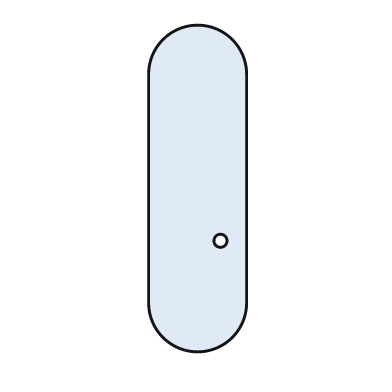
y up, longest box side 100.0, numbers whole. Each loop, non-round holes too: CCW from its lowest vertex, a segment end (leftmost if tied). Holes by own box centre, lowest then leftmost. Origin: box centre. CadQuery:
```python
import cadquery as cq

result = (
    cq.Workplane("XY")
    .moveTo(-15.0, -35.0)
    .threePointArc((0.0, -50.0), (15.0, -35.0))
    .lineTo(15.0, 35.0)
    .threePointArc((0.0, 50.0), (-15.0, 35.0))
    .close()
    .moveTo(7.0, -16.0)
    .circle(2.0)
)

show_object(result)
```